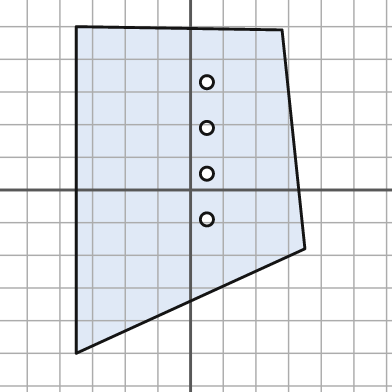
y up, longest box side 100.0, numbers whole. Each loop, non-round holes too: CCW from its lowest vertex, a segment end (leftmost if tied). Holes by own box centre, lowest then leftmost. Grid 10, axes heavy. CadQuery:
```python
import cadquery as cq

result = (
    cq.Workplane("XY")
    .moveTo(-35.0, -50.0)
    .lineTo(35.0, -18.0)
    .lineTo(28.0, 49.0)
    .lineTo(-35.0, 50.0)
    .close()
    .moveTo(5.0, -9.0)
    .circle(2.0)
    .moveTo(5.0, 5.0)
    .circle(2.0)
    .moveTo(5.0, 19.0)
    .circle(2.0)
    .moveTo(5.0, 33.0)
    .circle(2.0)
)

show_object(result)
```